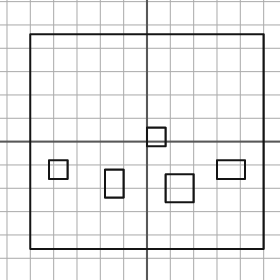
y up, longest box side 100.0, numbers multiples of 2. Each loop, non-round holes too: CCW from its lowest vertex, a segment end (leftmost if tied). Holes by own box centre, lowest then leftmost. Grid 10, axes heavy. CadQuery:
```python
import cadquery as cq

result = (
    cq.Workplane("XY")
    .moveTo(-50.0, -46.0)
    .lineTo(50.0, -46.0)
    .lineTo(50.0, 46.0)
    .lineTo(-50.0, 46.0)
    .close()
    .moveTo(8.0, -26.0)
    .lineTo(20.0, -26.0)
    .lineTo(20.0, -14.0)
    .lineTo(8.0, -14.0)
    .close()
    .moveTo(-18.0, -24.0)
    .lineTo(-10.0, -24.0)
    .lineTo(-10.0, -12.0)
    .lineTo(-18.0, -12.0)
    .close()
    .moveTo(-42.0, -16.0)
    .lineTo(-34.0, -16.0)
    .lineTo(-34.0, -8.0)
    .lineTo(-42.0, -8.0)
    .close()
    .moveTo(30.0, -16.0)
    .lineTo(42.0, -16.0)
    .lineTo(42.0, -8.0)
    .lineTo(30.0, -8.0)
    .close()
    .moveTo(0.0, -2.0)
    .lineTo(8.0, -2.0)
    .lineTo(8.0, 6.0)
    .lineTo(0.0, 6.0)
    .close()
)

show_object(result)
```